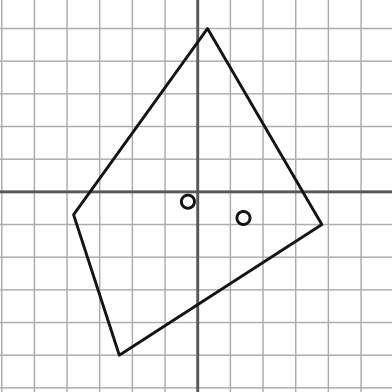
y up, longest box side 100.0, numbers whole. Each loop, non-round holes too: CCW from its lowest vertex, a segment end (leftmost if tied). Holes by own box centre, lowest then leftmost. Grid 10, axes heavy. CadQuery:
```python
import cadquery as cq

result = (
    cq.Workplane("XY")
    .moveTo(-24.0, -50.0)
    .lineTo(38.0, -10.0)
    .lineTo(3.0, 50.0)
    .lineTo(-38.0, -7.0)
    .close()
    .moveTo(14.0, -8.0)
    .circle(2.0)
    .moveTo(-3.0, -3.0)
    .circle(2.0)
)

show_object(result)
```